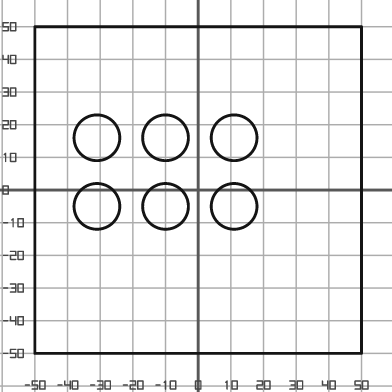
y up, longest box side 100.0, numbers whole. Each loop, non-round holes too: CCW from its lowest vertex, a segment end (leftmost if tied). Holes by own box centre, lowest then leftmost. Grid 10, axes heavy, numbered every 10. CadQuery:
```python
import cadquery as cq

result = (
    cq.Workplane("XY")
    .moveTo(-50.0, -50.0)
    .lineTo(50.0, -50.0)
    .lineTo(50.0, 50.0)
    .lineTo(-50.0, 50.0)
    .close()
    .moveTo(-31.0, -5.0)
    .circle(7.0)
    .moveTo(-10.0, -5.0)
    .circle(7.0)
    .moveTo(11.0, -5.0)
    .circle(7.0)
    .moveTo(-31.0, 16.0)
    .circle(7.0)
    .moveTo(-10.0, 16.0)
    .circle(7.0)
    .moveTo(11.0, 16.0)
    .circle(7.0)
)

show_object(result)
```